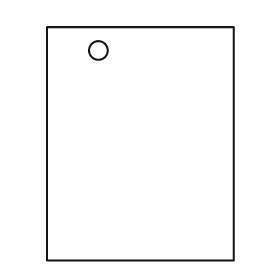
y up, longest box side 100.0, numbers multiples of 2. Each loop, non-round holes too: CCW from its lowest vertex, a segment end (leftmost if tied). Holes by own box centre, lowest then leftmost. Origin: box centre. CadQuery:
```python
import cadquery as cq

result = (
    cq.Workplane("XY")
    .moveTo(-40.0, -50.0)
    .lineTo(40.0, -50.0)
    .lineTo(40.0, 50.0)
    .lineTo(-40.0, 50.0)
    .close()
    .moveTo(-18.0, 40.0)
    .circle(4.0)
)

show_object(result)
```